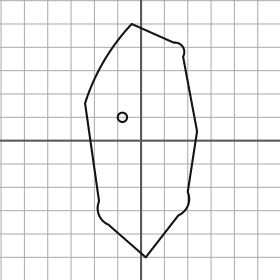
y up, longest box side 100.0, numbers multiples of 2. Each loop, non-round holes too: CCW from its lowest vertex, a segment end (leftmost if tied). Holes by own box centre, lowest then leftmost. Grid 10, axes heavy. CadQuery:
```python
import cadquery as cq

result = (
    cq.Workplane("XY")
    .moveTo(2.0, -50.0)
    .lineTo(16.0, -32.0)
    .threePointArc((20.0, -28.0), (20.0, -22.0))
    .lineTo(24.0, 4.0)
    .lineTo(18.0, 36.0)
    .threePointArc((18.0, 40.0), (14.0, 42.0))
    .lineTo(-4.0, 50.0)
    .threePointArc((-16.0, 34.0), (-24.0, 16.0))
    .lineTo(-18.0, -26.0)
    .threePointArc((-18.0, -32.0), (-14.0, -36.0))
    .close()
    .moveTo(-8.0, 10.0)
    .circle(2.0)
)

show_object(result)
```